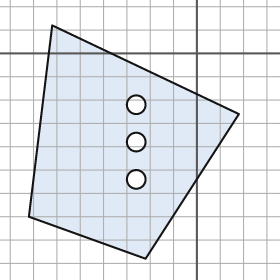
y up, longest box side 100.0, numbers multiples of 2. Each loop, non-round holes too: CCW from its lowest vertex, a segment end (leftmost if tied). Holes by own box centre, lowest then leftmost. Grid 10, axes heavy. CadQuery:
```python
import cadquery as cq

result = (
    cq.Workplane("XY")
    .moveTo(-22.0, -88.0)
    .lineTo(18.0, -26.0)
    .lineTo(-62.0, 12.0)
    .lineTo(-72.0, -70.0)
    .close()
    .moveTo(-26.0, -54.0)
    .circle(4.0)
    .moveTo(-26.0, -38.0)
    .circle(4.0)
    .moveTo(-26.0, -22.0)
    .circle(4.0)
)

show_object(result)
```